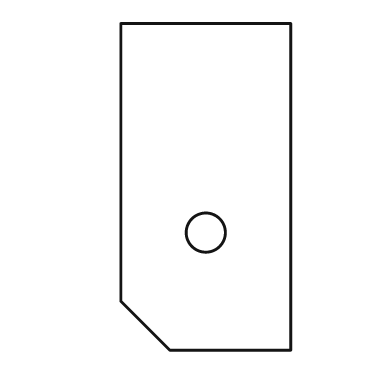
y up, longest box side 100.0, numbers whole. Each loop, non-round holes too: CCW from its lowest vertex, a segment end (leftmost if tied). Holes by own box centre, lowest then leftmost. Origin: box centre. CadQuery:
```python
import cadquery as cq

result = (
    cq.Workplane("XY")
    .moveTo(-11.0, -50.0)
    .lineTo(26.0, -50.0)
    .lineTo(26.0, 50.0)
    .lineTo(-26.0, 50.0)
    .lineTo(-26.0, -35.0)
    .close()
    .moveTo(0.0, -14.0)
    .circle(6.0)
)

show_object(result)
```